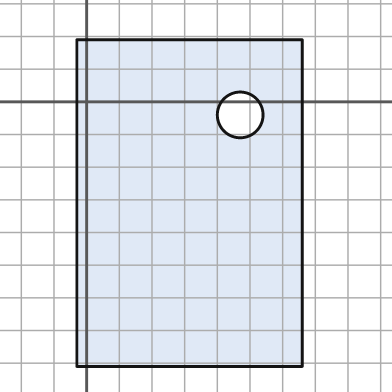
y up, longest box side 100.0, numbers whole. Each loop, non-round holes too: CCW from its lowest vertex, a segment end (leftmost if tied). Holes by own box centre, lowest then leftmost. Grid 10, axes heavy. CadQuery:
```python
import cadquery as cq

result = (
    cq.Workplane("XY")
    .moveTo(-3.0, -81.0)
    .lineTo(66.0, -81.0)
    .lineTo(66.0, 19.0)
    .lineTo(-3.0, 19.0)
    .close()
    .moveTo(47.0, -4.0)
    .circle(7.0)
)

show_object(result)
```